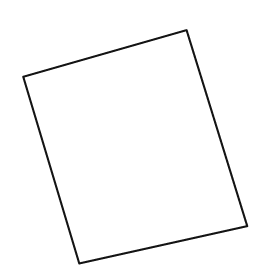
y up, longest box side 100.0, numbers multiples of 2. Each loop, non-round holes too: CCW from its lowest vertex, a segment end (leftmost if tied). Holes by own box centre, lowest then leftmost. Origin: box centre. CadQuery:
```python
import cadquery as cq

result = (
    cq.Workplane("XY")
    .moveTo(-24.0, -50.0)
    .lineTo(48.0, -34.0)
    .lineTo(22.0, 50.0)
    .lineTo(-48.0, 30.0)
    .close()
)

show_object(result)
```